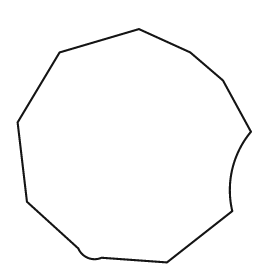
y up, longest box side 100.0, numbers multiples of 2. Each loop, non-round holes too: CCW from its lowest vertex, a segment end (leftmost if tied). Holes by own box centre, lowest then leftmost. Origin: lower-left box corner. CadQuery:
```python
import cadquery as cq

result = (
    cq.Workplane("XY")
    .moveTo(64.0, 0.0)
    .lineTo(92.0, 22.0)
    .threePointArc((92.0, 40.0), (100.0, 56.0))
    .lineTo(88.0, 78.0)
    .lineTo(74.0, 90.0)
    .lineTo(52.0, 100.0)
    .lineTo(18.0, 90.0)
    .lineTo(0.0, 60.0)
    .lineTo(4.0, 26.0)
    .lineTo(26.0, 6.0)
    .threePointArc((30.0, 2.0), (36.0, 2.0))
    .close()
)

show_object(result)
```